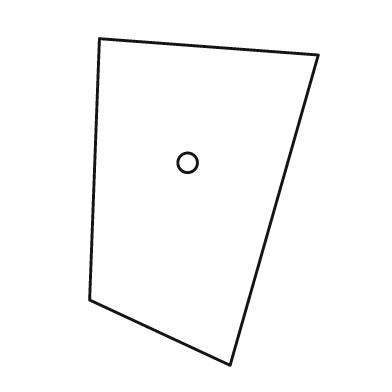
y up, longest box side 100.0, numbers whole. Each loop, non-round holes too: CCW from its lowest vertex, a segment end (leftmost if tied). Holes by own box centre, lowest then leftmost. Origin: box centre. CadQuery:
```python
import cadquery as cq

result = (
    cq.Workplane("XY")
    .moveTo(8.0, -50.0)
    .lineTo(35.0, 45.0)
    .lineTo(-32.0, 50.0)
    .lineTo(-35.0, -30.0)
    .close()
    .moveTo(-5.0, 12.0)
    .circle(3.0)
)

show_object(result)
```